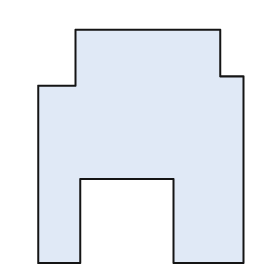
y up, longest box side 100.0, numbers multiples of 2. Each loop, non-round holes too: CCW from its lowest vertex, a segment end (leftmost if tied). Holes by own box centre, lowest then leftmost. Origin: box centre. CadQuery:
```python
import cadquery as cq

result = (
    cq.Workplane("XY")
    .moveTo(-44.0, -50.0)
    .lineTo(-26.0, -50.0)
    .lineTo(-26.0, -14.0)
    .lineTo(14.0, -14.0)
    .lineTo(14.0, -50.0)
    .lineTo(44.0, -50.0)
    .lineTo(44.0, 30.0)
    .lineTo(34.0, 30.0)
    .lineTo(34.0, 50.0)
    .lineTo(-28.0, 50.0)
    .lineTo(-28.0, 26.0)
    .lineTo(-44.0, 26.0)
    .close()
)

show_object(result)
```